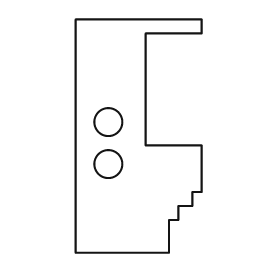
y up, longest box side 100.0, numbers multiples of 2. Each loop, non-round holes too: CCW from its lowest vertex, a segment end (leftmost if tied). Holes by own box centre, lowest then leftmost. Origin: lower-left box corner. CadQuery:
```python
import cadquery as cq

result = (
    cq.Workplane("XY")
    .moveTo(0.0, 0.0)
    .lineTo(40.0, 0.0)
    .lineTo(40.0, 14.0)
    .lineTo(44.0, 14.0)
    .lineTo(44.0, 20.0)
    .lineTo(50.0, 20.0)
    .lineTo(50.0, 26.0)
    .lineTo(54.0, 26.0)
    .lineTo(54.0, 46.0)
    .lineTo(30.0, 46.0)
    .lineTo(30.0, 94.0)
    .lineTo(54.0, 94.0)
    .lineTo(54.0, 100.0)
    .lineTo(0.0, 100.0)
    .close()
    .moveTo(14.0, 38.0)
    .circle(6.0)
    .moveTo(14.0, 56.0)
    .circle(6.0)
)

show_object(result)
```